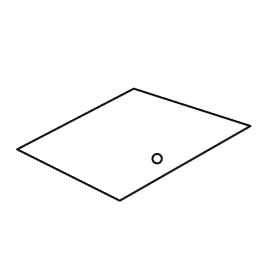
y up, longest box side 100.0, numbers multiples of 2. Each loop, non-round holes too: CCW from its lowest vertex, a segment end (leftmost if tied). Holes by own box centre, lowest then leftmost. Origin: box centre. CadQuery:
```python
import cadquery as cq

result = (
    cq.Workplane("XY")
    .moveTo(-6.0, -24.0)
    .lineTo(50.0, 8.0)
    .lineTo(0.0, 24.0)
    .lineTo(-50.0, -2.0)
    .close()
    .moveTo(10.0, -6.0)
    .circle(2.0)
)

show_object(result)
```